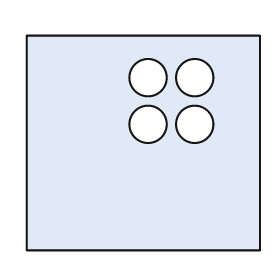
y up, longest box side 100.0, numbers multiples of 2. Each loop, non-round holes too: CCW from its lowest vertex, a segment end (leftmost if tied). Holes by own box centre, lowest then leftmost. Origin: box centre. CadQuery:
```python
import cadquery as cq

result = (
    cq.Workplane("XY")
    .moveTo(-50.0, -46.0)
    .lineTo(50.0, -46.0)
    .lineTo(50.0, 46.0)
    .lineTo(-50.0, 46.0)
    .close()
    .moveTo(2.0, 8.0)
    .circle(8.0)
    .moveTo(22.0, 8.0)
    .circle(8.0)
    .moveTo(2.0, 28.0)
    .circle(8.0)
    .moveTo(22.0, 28.0)
    .circle(8.0)
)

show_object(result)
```